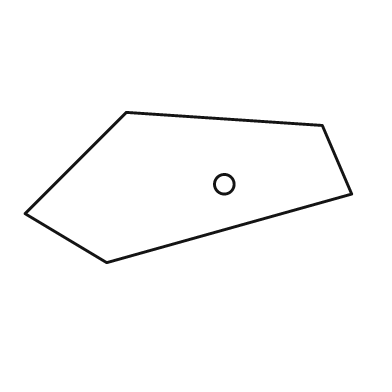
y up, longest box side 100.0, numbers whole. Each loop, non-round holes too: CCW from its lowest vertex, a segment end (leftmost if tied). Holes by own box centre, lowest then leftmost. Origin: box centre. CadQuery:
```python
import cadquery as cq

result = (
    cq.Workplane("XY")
    .moveTo(-25.0, -23.0)
    .lineTo(50.0, -2.0)
    .lineTo(41.0, 19.0)
    .lineTo(-19.0, 23.0)
    .lineTo(-50.0, -8.0)
    .close()
    .moveTo(11.0, 1.0)
    .circle(3.0)
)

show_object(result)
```